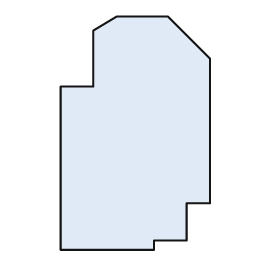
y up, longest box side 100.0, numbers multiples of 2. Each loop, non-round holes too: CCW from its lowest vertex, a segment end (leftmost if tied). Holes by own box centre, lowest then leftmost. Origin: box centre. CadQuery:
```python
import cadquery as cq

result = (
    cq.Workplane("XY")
    .moveTo(-32.0, -50.0)
    .lineTo(8.0, -50.0)
    .lineTo(8.0, -46.0)
    .lineTo(22.0, -46.0)
    .lineTo(22.0, -30.0)
    .lineTo(32.0, -30.0)
    .lineTo(32.0, 32.0)
    .lineTo(14.0, 50.0)
    .lineTo(-8.0, 50.0)
    .lineTo(-18.0, 44.0)
    .lineTo(-18.0, 20.0)
    .lineTo(-32.0, 20.0)
    .close()
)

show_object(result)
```